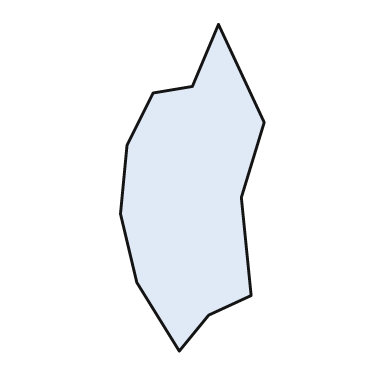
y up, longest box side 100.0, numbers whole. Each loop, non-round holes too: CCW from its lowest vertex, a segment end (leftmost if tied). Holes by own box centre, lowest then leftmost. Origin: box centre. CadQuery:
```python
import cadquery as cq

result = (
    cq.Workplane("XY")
    .moveTo(-4.0, -50.0)
    .lineTo(5.0, -39.0)
    .lineTo(18.0, -33.0)
    .lineTo(15.0, -3.0)
    .lineTo(22.0, 20.0)
    .lineTo(8.0, 50.0)
    .lineTo(0.0, 31.0)
    .lineTo(-12.0, 29.0)
    .lineTo(-20.0, 13.0)
    .lineTo(-22.0, -8.0)
    .lineTo(-17.0, -29.0)
    .close()
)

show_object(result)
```